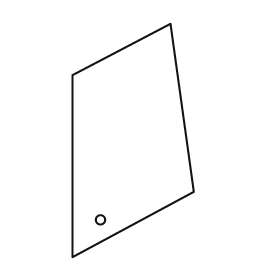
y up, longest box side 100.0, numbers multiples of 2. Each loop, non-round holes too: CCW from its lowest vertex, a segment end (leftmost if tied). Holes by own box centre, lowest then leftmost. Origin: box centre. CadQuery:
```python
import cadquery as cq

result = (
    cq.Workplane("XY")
    .moveTo(-26.0, -50.0)
    .lineTo(26.0, -22.0)
    .lineTo(16.0, 50.0)
    .lineTo(-26.0, 28.0)
    .close()
    .moveTo(-14.0, -34.0)
    .circle(2.0)
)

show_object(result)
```